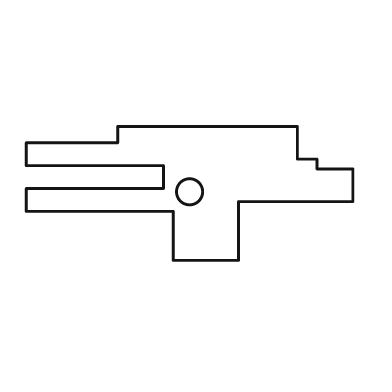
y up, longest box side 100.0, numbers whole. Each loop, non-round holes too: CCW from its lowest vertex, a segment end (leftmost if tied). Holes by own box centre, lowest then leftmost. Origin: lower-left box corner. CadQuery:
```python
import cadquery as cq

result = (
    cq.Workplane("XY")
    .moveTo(45.0, 0.0)
    .lineTo(65.0, 0.0)
    .lineTo(65.0, 18.0)
    .lineTo(100.0, 18.0)
    .lineTo(100.0, 28.0)
    .lineTo(89.0, 28.0)
    .lineTo(89.0, 31.0)
    .lineTo(83.0, 31.0)
    .lineTo(83.0, 41.0)
    .lineTo(28.0, 41.0)
    .lineTo(28.0, 36.0)
    .lineTo(0.0, 36.0)
    .lineTo(0.0, 29.0)
    .lineTo(42.0, 29.0)
    .lineTo(42.0, 22.0)
    .lineTo(0.0, 22.0)
    .lineTo(0.0, 15.0)
    .lineTo(45.0, 15.0)
    .close()
    .moveTo(50.0, 21.0)
    .circle(4.0)
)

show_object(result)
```